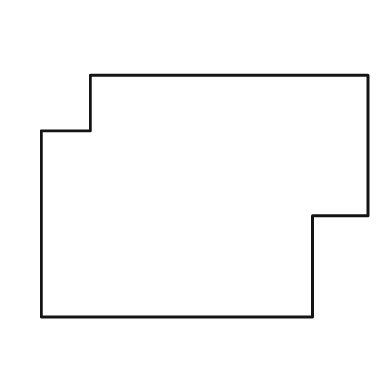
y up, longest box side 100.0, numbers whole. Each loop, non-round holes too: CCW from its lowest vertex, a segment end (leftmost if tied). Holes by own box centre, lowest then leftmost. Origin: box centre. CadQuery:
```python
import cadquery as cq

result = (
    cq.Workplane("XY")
    .moveTo(-50.0, -37.0)
    .lineTo(33.0, -37.0)
    .lineTo(33.0, -6.0)
    .lineTo(50.0, -6.0)
    .lineTo(50.0, 37.0)
    .lineTo(-35.0, 37.0)
    .lineTo(-35.0, 20.0)
    .lineTo(-50.0, 20.0)
    .close()
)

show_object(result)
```